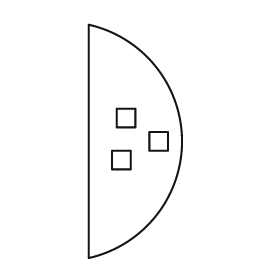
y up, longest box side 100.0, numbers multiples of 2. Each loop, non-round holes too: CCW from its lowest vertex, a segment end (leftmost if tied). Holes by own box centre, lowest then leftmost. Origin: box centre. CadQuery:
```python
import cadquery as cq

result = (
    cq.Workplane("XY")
    .moveTo(-20.0, -50.0)
    .threePointArc((20.0, 0.0), (-20.0, 50.0))
    .close()
    .moveTo(-10.0, -12.0)
    .lineTo(-2.0, -12.0)
    .lineTo(-2.0, -4.0)
    .lineTo(-10.0, -4.0)
    .close()
    .moveTo(6.0, -4.0)
    .lineTo(14.0, -4.0)
    .lineTo(14.0, 4.0)
    .lineTo(6.0, 4.0)
    .close()
    .moveTo(-8.0, 6.0)
    .lineTo(0.0, 6.0)
    .lineTo(0.0, 14.0)
    .lineTo(-8.0, 14.0)
    .close()
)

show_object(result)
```